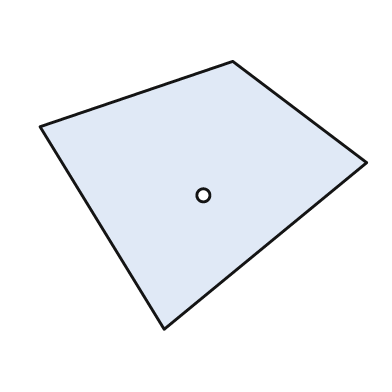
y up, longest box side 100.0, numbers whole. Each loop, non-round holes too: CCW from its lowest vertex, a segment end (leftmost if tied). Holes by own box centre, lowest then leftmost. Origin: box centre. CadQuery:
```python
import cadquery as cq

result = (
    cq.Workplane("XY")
    .moveTo(-12.0, -41.0)
    .lineTo(50.0, 10.0)
    .lineTo(9.0, 41.0)
    .lineTo(-50.0, 21.0)
    .close()
    .moveTo(0.0, 0.0)
    .circle(2.0)
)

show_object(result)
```